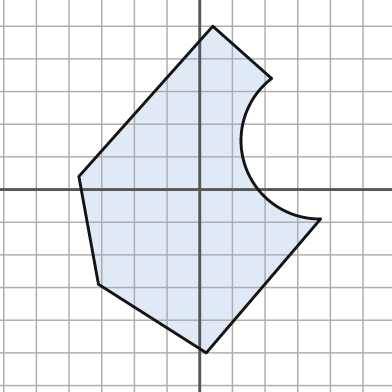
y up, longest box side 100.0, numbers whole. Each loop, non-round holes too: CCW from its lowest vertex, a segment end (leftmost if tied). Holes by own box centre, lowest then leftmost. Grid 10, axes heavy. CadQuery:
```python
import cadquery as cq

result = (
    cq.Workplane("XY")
    .moveTo(2.0, -50.0)
    .lineTo(37.0, -9.0)
    .threePointArc((14.0, 7.0), (22.0, 34.0))
    .lineTo(4.0, 50.0)
    .lineTo(-37.0, 4.0)
    .lineTo(-31.0, -29.0)
    .close()
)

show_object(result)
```